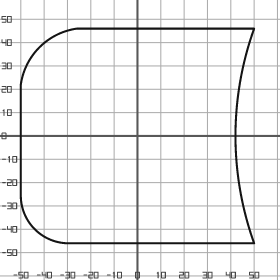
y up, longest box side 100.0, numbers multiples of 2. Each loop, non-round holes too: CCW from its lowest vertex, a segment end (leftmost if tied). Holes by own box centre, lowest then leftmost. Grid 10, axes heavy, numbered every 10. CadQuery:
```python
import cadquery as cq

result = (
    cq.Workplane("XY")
    .moveTo(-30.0, -46.0)
    .lineTo(50.0, -46.0)
    .threePointArc((42.0, 0.0), (50.0, 46.0))
    .lineTo(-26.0, 46.0)
    .threePointArc((-42.0, 38.0), (-50.0, 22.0))
    .lineTo(-50.0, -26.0)
    .threePointArc((-44.0, -40.0), (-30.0, -46.0))
    .close()
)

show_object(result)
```